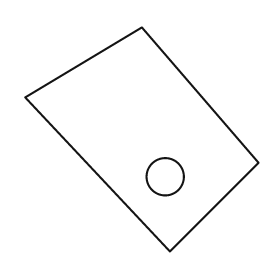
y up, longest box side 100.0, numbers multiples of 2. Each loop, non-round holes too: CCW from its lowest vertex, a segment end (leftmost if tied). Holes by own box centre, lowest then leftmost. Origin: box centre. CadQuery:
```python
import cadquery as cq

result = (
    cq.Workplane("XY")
    .moveTo(12.0, -48.0)
    .lineTo(50.0, -10.0)
    .lineTo(0.0, 48.0)
    .lineTo(-50.0, 18.0)
    .close()
    .moveTo(10.0, -16.0)
    .circle(8.0)
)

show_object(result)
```